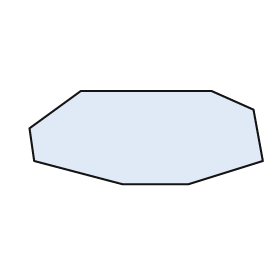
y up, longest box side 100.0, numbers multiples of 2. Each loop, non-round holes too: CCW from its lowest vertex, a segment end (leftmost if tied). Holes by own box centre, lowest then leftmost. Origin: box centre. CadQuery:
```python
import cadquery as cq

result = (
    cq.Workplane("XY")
    .moveTo(-10.0, -20.0)
    .lineTo(18.0, -20.0)
    .lineTo(50.0, -10.0)
    .lineTo(46.0, 12.0)
    .lineTo(28.0, 20.0)
    .lineTo(-28.0, 20.0)
    .lineTo(-50.0, 4.0)
    .lineTo(-48.0, -10.0)
    .close()
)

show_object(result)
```